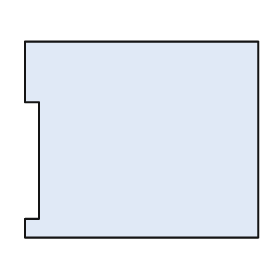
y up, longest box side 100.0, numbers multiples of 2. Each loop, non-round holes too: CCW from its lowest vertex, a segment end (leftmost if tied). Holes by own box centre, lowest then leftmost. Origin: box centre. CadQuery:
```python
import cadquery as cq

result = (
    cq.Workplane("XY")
    .moveTo(-50.0, -42.0)
    .lineTo(50.0, -42.0)
    .lineTo(50.0, 42.0)
    .lineTo(-50.0, 42.0)
    .lineTo(-50.0, 16.0)
    .lineTo(-44.0, 16.0)
    .lineTo(-44.0, -34.0)
    .lineTo(-50.0, -34.0)
    .close()
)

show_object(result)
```